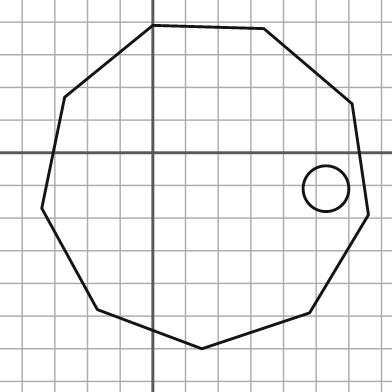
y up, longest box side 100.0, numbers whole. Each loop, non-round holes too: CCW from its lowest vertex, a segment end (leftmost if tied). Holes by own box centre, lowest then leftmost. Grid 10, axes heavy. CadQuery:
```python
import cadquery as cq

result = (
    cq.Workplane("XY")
    .moveTo(15.0, -60.0)
    .lineTo(48.0, -49.0)
    .lineTo(66.0, -19.0)
    .lineTo(61.0, 15.0)
    .lineTo(34.0, 38.0)
    .lineTo(0.0, 39.0)
    .lineTo(-27.0, 17.0)
    .lineTo(-34.0, -17.0)
    .lineTo(-17.0, -48.0)
    .close()
    .moveTo(53.0, -11.0)
    .circle(7.0)
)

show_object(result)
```